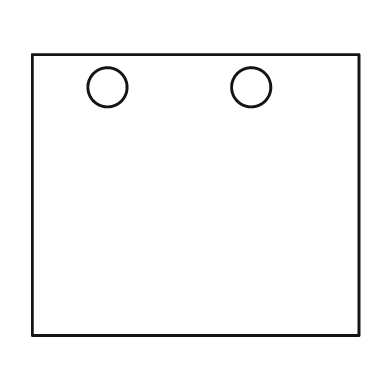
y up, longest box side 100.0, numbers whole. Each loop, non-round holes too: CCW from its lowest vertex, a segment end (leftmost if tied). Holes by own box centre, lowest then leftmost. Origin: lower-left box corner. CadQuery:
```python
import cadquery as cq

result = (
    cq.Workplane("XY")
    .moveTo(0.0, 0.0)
    .lineTo(100.0, 0.0)
    .lineTo(100.0, 86.0)
    .lineTo(0.0, 86.0)
    .close()
    .moveTo(23.0, 76.0)
    .circle(6.0)
    .moveTo(67.0, 76.0)
    .circle(6.0)
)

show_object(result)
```